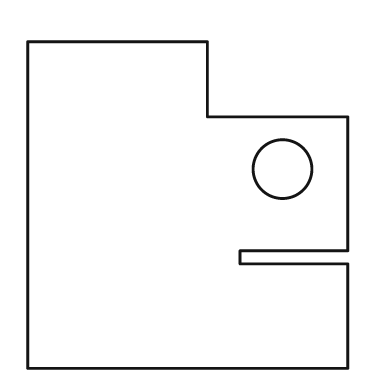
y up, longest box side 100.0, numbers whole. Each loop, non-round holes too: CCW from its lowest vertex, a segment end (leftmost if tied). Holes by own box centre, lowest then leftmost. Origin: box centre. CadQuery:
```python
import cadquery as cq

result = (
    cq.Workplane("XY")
    .moveTo(-49.0, -50.0)
    .lineTo(49.0, -50.0)
    .lineTo(49.0, -18.0)
    .lineTo(16.0, -18.0)
    .lineTo(16.0, -14.0)
    .lineTo(49.0, -14.0)
    .lineTo(49.0, 27.0)
    .lineTo(6.0, 27.0)
    .lineTo(6.0, 50.0)
    .lineTo(-49.0, 50.0)
    .close()
    .moveTo(29.0, 11.0)
    .circle(9.0)
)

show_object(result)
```